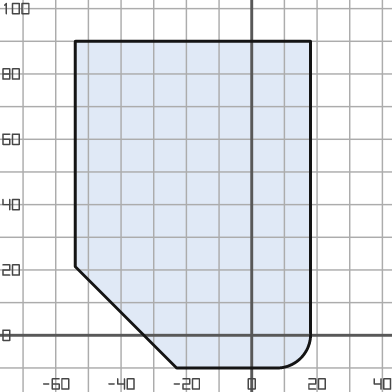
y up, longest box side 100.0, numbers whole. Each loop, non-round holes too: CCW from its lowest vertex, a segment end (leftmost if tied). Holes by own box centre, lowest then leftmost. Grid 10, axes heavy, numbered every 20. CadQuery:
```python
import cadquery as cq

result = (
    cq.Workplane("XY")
    .moveTo(-23.0, -10.0)
    .lineTo(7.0, -10.0)
    .threePointArc((15.0, -7.0), (18.0, 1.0))
    .lineTo(18.0, 90.0)
    .lineTo(-54.0, 90.0)
    .lineTo(-54.0, 21.0)
    .close()
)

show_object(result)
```